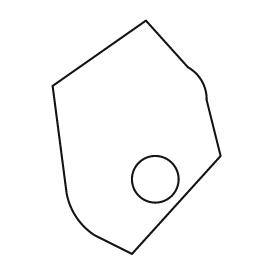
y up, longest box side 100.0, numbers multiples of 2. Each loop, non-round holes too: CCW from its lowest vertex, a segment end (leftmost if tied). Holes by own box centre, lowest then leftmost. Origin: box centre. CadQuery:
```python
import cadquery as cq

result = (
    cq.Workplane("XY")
    .moveTo(-2.0, -50.0)
    .lineTo(36.0, -8.0)
    .lineTo(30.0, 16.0)
    .threePointArc((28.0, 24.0), (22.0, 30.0))
    .lineTo(4.0, 50.0)
    .lineTo(-36.0, 22.0)
    .lineTo(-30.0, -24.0)
    .threePointArc((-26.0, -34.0), (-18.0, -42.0))
    .close()
    .moveTo(8.0, -18.0)
    .circle(10.0)
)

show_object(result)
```